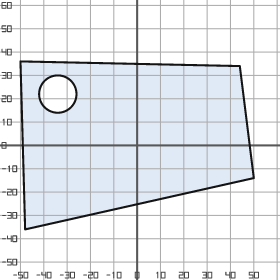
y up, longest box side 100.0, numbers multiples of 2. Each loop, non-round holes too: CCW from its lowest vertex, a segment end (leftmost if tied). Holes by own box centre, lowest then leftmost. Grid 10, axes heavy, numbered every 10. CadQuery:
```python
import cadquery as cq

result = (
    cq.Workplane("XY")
    .moveTo(-48.0, -36.0)
    .lineTo(50.0, -14.0)
    .lineTo(44.0, 34.0)
    .lineTo(-50.0, 36.0)
    .close()
    .moveTo(-34.0, 22.0)
    .circle(8.0)
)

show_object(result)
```